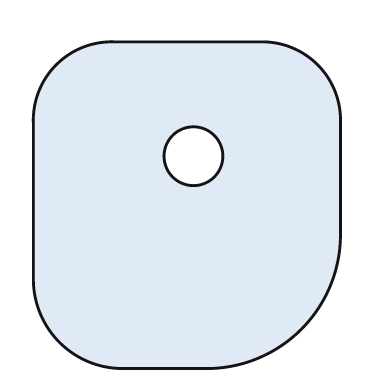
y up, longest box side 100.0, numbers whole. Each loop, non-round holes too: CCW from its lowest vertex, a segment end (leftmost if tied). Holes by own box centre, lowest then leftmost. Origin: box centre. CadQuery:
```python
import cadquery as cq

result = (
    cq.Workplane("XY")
    .moveTo(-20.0, -50.0)
    .lineTo(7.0, -50.0)
    .threePointArc((35.0, -38.0), (47.0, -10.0))
    .lineTo(47.0, 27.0)
    .threePointArc((40.0, 43.0), (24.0, 50.0))
    .lineTo(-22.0, 50.0)
    .threePointArc((-40.0, 43.0), (-47.0, 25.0))
    .lineTo(-47.0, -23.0)
    .threePointArc((-39.0, -42.0), (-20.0, -50.0))
    .close()
    .moveTo(2.0, 15.0)
    .circle(9.0)
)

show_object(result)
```